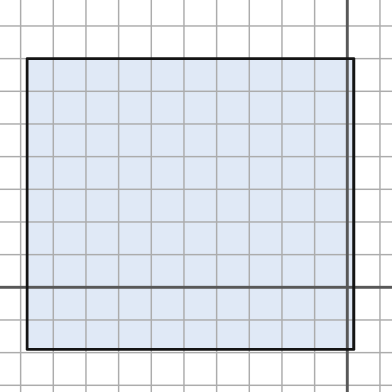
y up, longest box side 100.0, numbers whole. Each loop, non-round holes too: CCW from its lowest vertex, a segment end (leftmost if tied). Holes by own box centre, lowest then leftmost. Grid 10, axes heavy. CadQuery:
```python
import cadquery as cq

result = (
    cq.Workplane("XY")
    .moveTo(-98.0, -19.0)
    .lineTo(2.0, -19.0)
    .lineTo(2.0, 70.0)
    .lineTo(-98.0, 70.0)
    .close()
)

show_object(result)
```